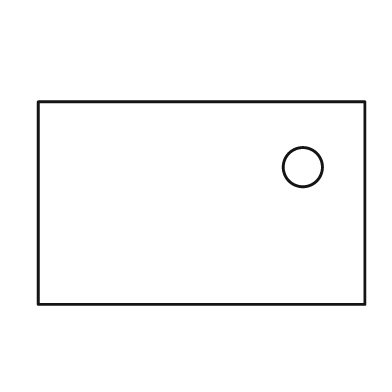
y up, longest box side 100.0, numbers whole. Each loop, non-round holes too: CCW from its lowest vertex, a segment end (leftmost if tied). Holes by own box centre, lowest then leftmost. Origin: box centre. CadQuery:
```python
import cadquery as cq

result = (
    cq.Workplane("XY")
    .moveTo(-50.0, -31.0)
    .lineTo(50.0, -31.0)
    .lineTo(50.0, 31.0)
    .lineTo(-50.0, 31.0)
    .close()
    .moveTo(31.0, 11.0)
    .circle(6.0)
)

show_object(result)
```